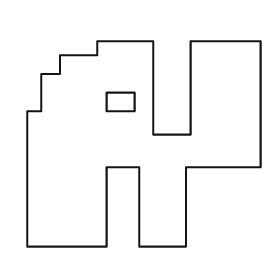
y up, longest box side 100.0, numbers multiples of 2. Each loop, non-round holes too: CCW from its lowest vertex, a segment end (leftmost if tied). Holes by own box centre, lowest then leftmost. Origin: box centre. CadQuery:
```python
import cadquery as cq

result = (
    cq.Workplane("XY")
    .moveTo(-50.0, -44.0)
    .lineTo(-16.0, -44.0)
    .lineTo(-16.0, -10.0)
    .lineTo(-2.0, -10.0)
    .lineTo(-2.0, -44.0)
    .lineTo(18.0, -44.0)
    .lineTo(18.0, -10.0)
    .lineTo(50.0, -10.0)
    .lineTo(50.0, 44.0)
    .lineTo(20.0, 44.0)
    .lineTo(20.0, 4.0)
    .lineTo(4.0, 4.0)
    .lineTo(4.0, 44.0)
    .lineTo(-20.0, 44.0)
    .lineTo(-20.0, 38.0)
    .lineTo(-36.0, 38.0)
    .lineTo(-36.0, 30.0)
    .lineTo(-44.0, 30.0)
    .lineTo(-44.0, 14.0)
    .lineTo(-50.0, 14.0)
    .close()
    .moveTo(-16.0, 14.0)
    .lineTo(-4.0, 14.0)
    .lineTo(-4.0, 22.0)
    .lineTo(-16.0, 22.0)
    .close()
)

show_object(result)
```